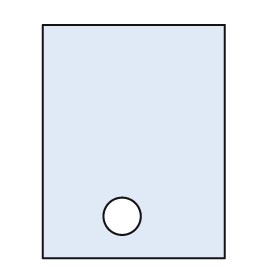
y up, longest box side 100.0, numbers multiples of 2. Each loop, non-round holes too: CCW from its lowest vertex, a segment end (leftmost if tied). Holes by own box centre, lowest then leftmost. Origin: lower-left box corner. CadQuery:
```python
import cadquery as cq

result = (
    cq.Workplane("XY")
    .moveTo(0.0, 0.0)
    .lineTo(78.0, 0.0)
    .lineTo(78.0, 100.0)
    .lineTo(0.0, 100.0)
    .close()
    .moveTo(34.0, 18.0)
    .circle(8.0)
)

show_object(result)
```